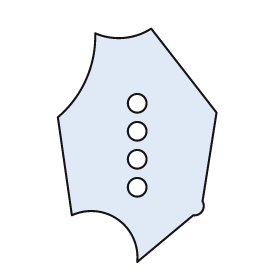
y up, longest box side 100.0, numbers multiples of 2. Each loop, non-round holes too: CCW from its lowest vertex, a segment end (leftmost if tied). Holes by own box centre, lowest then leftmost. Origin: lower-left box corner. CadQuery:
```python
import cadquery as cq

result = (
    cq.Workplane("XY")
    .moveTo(34.0, 0.0)
    .lineTo(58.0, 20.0)
    .threePointArc((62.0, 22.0), (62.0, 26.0))
    .lineTo(68.0, 64.0)
    .lineTo(40.0, 100.0)
    .threePointArc((28.0, 96.0), (16.0, 98.0))
    .threePointArc((12.0, 78.0), (0.0, 62.0))
    .lineTo(6.0, 20.0)
    .threePointArc((26.0, 18.0), (34.0, 0.0))
    .close()
    .moveTo(34.0, 32.0)
    .circle(4.0)
    .moveTo(34.0, 44.0)
    .circle(4.0)
    .moveTo(34.0, 56.0)
    .circle(4.0)
    .moveTo(34.0, 68.0)
    .circle(4.0)
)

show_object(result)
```